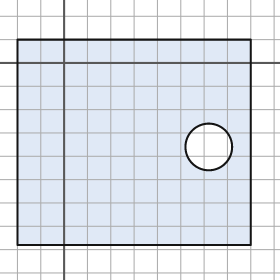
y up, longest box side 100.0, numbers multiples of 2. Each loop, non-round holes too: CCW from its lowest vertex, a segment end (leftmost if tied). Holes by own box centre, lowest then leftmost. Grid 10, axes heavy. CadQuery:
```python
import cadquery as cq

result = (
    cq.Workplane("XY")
    .moveTo(-20.0, -78.0)
    .lineTo(80.0, -78.0)
    .lineTo(80.0, 10.0)
    .lineTo(-20.0, 10.0)
    .close()
    .moveTo(62.0, -36.0)
    .circle(10.0)
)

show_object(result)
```